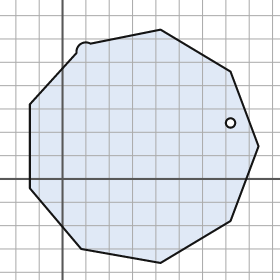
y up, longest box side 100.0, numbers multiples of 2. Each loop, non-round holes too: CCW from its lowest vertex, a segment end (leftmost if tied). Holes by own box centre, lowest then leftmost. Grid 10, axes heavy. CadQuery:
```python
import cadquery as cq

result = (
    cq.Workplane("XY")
    .moveTo(42.0, -36.0)
    .lineTo(72.0, -18.0)
    .lineTo(84.0, 14.0)
    .lineTo(72.0, 46.0)
    .lineTo(42.0, 64.0)
    .lineTo(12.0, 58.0)
    .threePointArc((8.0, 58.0), (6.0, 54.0))
    .lineTo(-14.0, 32.0)
    .lineTo(-14.0, -4.0)
    .lineTo(8.0, -30.0)
    .close()
    .moveTo(72.0, 24.0)
    .circle(2.0)
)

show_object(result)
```